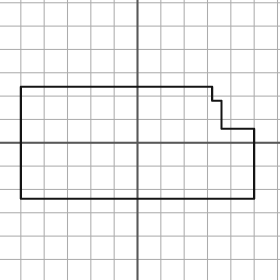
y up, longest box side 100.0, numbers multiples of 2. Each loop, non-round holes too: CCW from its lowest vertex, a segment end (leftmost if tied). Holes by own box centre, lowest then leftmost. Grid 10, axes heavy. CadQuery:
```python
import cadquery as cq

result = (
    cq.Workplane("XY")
    .moveTo(-50.0, -24.0)
    .lineTo(50.0, -24.0)
    .lineTo(50.0, 6.0)
    .lineTo(36.0, 6.0)
    .lineTo(36.0, 18.0)
    .lineTo(32.0, 18.0)
    .lineTo(32.0, 24.0)
    .lineTo(-50.0, 24.0)
    .close()
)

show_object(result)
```